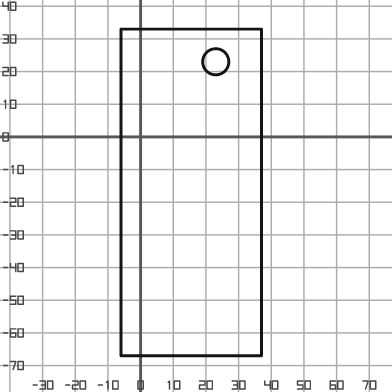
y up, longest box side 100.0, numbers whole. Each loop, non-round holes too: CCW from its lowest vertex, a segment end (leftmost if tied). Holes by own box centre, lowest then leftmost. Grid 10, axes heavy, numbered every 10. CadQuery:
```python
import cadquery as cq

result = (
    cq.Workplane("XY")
    .moveTo(-6.0, -67.0)
    .lineTo(37.0, -67.0)
    .lineTo(37.0, 33.0)
    .lineTo(-6.0, 33.0)
    .close()
    .moveTo(23.0, 23.0)
    .circle(4.0)
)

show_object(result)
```